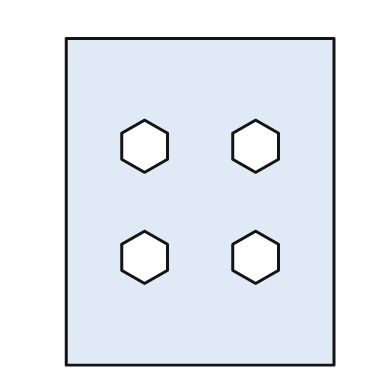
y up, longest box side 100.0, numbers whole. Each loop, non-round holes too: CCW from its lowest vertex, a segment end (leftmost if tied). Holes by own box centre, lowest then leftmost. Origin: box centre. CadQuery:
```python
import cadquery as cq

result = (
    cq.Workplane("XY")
    .moveTo(-41.0, -50.0)
    .lineTo(41.0, -50.0)
    .lineTo(41.0, 50.0)
    .lineTo(-41.0, 50.0)
    .close()
    .moveTo(-17.0, -25.0)
    .lineTo(-10.0, -21.0)
    .lineTo(-10.0, -13.0)
    .lineTo(-17.0, -9.0)
    .lineTo(-24.0, -13.0)
    .lineTo(-24.0, -21.0)
    .close()
    .moveTo(17.0, -25.0)
    .lineTo(24.0, -21.0)
    .lineTo(24.0, -13.0)
    .lineTo(17.0, -9.0)
    .lineTo(10.0, -13.0)
    .lineTo(10.0, -21.0)
    .close()
    .moveTo(-17.0, 9.0)
    .lineTo(-10.0, 13.0)
    .lineTo(-10.0, 21.0)
    .lineTo(-17.0, 25.0)
    .lineTo(-24.0, 21.0)
    .lineTo(-24.0, 13.0)
    .close()
    .moveTo(17.0, 9.0)
    .lineTo(24.0, 13.0)
    .lineTo(24.0, 21.0)
    .lineTo(17.0, 25.0)
    .lineTo(10.0, 21.0)
    .lineTo(10.0, 13.0)
    .close()
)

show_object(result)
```